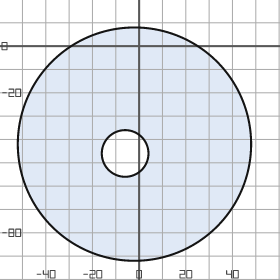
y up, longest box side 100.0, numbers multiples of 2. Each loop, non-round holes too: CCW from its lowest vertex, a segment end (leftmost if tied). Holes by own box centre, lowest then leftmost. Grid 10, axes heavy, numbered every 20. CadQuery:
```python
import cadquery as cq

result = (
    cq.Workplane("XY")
    .moveTo(-2.0, -42.0)
    .circle(50.0)
    .moveTo(-6.0, -46.0)
    .circle(10.0)
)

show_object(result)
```